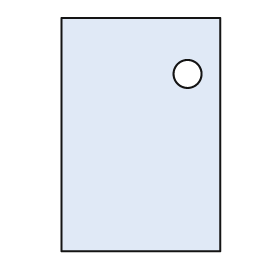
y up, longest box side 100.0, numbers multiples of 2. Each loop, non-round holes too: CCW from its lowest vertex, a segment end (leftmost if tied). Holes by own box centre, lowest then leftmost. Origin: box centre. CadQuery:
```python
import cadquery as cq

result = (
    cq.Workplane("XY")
    .moveTo(-34.0, -50.0)
    .lineTo(34.0, -50.0)
    .lineTo(34.0, 50.0)
    .lineTo(-34.0, 50.0)
    .close()
    .moveTo(20.0, 26.0)
    .circle(6.0)
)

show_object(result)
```